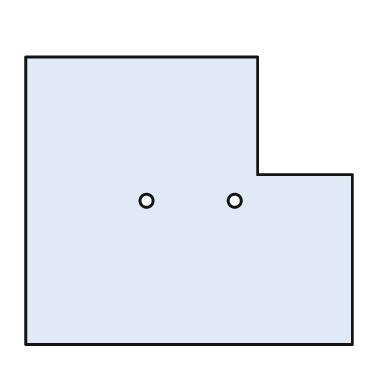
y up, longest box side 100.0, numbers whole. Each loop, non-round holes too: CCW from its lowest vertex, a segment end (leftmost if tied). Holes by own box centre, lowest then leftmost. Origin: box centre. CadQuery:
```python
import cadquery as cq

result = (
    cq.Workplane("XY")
    .moveTo(-50.0, -44.0)
    .lineTo(50.0, -44.0)
    .lineTo(50.0, 8.0)
    .lineTo(21.0, 8.0)
    .lineTo(21.0, 44.0)
    .lineTo(-50.0, 44.0)
    .close()
    .moveTo(-13.0, 0.0)
    .circle(2.0)
    .moveTo(14.0, 0.0)
    .circle(2.0)
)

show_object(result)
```